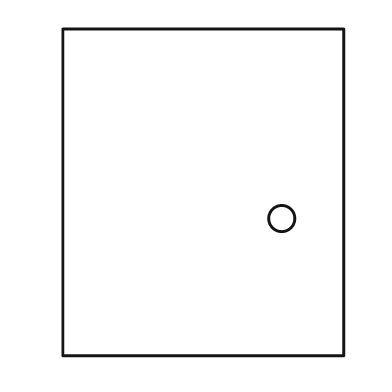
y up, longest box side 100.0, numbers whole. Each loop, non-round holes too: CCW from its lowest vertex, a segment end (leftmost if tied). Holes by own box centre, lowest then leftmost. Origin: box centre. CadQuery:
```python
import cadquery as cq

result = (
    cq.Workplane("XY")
    .moveTo(-43.0, -50.0)
    .lineTo(43.0, -50.0)
    .lineTo(43.0, 50.0)
    .lineTo(-43.0, 50.0)
    .close()
    .moveTo(24.0, -8.0)
    .circle(4.0)
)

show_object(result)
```